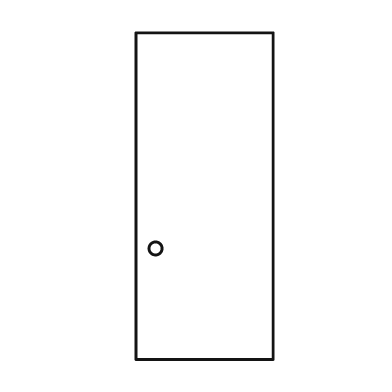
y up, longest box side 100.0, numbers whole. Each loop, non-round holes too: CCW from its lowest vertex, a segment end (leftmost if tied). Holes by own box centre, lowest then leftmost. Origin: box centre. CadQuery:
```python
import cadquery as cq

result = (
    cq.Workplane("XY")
    .moveTo(-21.0, -50.0)
    .lineTo(21.0, -50.0)
    .lineTo(21.0, 50.0)
    .lineTo(-21.0, 50.0)
    .close()
    .moveTo(-15.0, -16.0)
    .circle(2.0)
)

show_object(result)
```